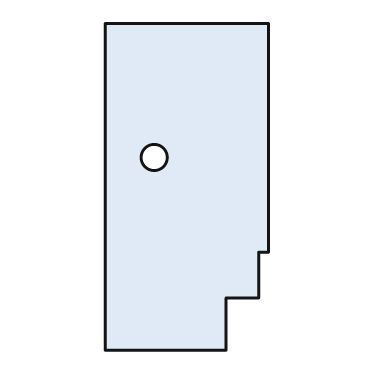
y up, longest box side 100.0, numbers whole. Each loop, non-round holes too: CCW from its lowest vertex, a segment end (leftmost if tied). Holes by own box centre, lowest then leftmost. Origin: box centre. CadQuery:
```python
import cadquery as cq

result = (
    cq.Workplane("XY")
    .moveTo(-25.0, -50.0)
    .lineTo(12.0, -50.0)
    .lineTo(12.0, -34.0)
    .lineTo(22.0, -34.0)
    .lineTo(22.0, -20.0)
    .lineTo(25.0, -20.0)
    .lineTo(25.0, 50.0)
    .lineTo(-25.0, 50.0)
    .close()
    .moveTo(-10.0, 9.0)
    .circle(4.0)
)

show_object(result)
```